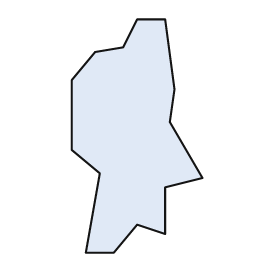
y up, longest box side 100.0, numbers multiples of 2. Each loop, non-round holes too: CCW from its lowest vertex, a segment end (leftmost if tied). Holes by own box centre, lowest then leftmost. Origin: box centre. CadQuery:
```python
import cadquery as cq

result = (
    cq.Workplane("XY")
    .moveTo(-22.0, -50.0)
    .lineTo(-10.0, -50.0)
    .lineTo(0.0, -38.0)
    .lineTo(12.0, -42.0)
    .lineTo(12.0, -22.0)
    .lineTo(28.0, -18.0)
    .lineTo(14.0, 6.0)
    .lineTo(16.0, 20.0)
    .lineTo(12.0, 50.0)
    .lineTo(0.0, 50.0)
    .lineTo(-6.0, 38.0)
    .lineTo(-18.0, 36.0)
    .lineTo(-28.0, 24.0)
    .lineTo(-28.0, -6.0)
    .lineTo(-16.0, -16.0)
    .close()
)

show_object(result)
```